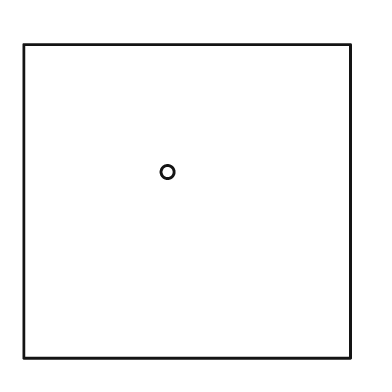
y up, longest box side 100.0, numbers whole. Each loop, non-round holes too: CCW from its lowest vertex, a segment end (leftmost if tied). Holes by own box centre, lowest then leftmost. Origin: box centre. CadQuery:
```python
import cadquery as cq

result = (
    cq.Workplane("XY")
    .moveTo(-50.0, -48.0)
    .lineTo(50.0, -48.0)
    .lineTo(50.0, 48.0)
    .lineTo(-50.0, 48.0)
    .close()
    .moveTo(-6.0, 9.0)
    .circle(2.0)
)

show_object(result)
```